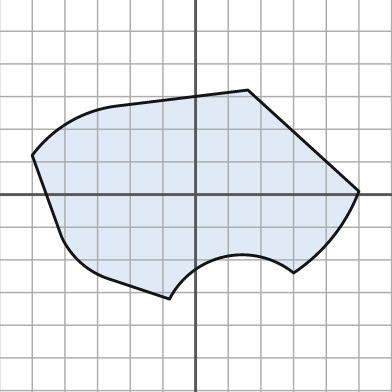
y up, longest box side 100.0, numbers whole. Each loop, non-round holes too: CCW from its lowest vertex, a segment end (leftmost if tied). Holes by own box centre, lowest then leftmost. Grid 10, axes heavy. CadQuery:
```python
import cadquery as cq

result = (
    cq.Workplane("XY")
    .moveTo(-8.0, -32.0)
    .threePointArc((9.0, -19.0), (30.0, -24.0))
    .threePointArc((42.0, -13.0), (50.0, 1.0))
    .lineTo(16.0, 32.0)
    .lineTo(-25.0, 27.0)
    .threePointArc((-39.0, 22.0), (-50.0, 12.0))
    .lineTo(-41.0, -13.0)
    .threePointArc((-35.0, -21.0), (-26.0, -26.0))
    .close()
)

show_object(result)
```